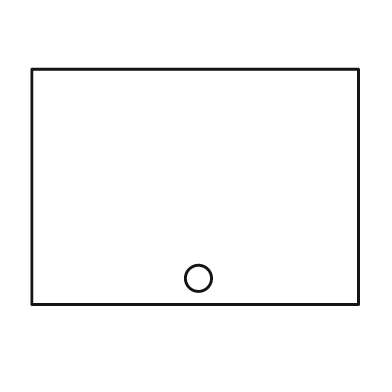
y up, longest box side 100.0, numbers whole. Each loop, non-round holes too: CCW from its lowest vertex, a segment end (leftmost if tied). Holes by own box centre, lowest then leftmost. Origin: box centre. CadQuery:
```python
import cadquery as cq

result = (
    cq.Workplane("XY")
    .moveTo(-50.0, -36.0)
    .lineTo(50.0, -36.0)
    .lineTo(50.0, 36.0)
    .lineTo(-50.0, 36.0)
    .close()
    .moveTo(1.0, -28.0)
    .circle(4.0)
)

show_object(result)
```